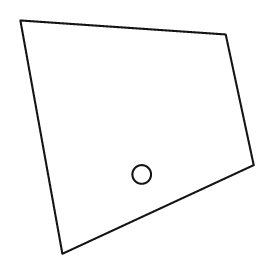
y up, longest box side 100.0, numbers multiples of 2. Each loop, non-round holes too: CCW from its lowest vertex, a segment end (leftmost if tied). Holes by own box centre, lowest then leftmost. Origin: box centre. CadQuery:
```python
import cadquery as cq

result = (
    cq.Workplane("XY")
    .moveTo(-32.0, -50.0)
    .lineTo(50.0, -12.0)
    .lineTo(38.0, 44.0)
    .lineTo(-50.0, 50.0)
    .close()
    .moveTo(2.0, -16.0)
    .circle(4.0)
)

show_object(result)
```